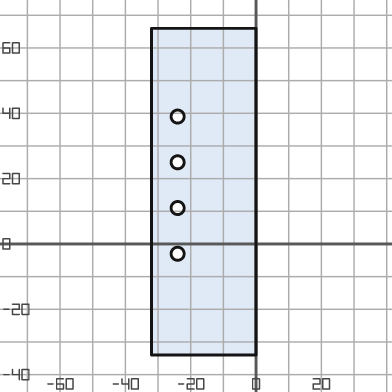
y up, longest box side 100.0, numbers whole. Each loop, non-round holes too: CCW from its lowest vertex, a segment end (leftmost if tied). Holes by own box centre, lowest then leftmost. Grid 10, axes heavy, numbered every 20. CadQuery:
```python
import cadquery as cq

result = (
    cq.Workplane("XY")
    .moveTo(-32.0, -34.0)
    .lineTo(0.0, -34.0)
    .lineTo(0.0, 66.0)
    .lineTo(-32.0, 66.0)
    .close()
    .moveTo(-24.0, -3.0)
    .circle(2.0)
    .moveTo(-24.0, 11.0)
    .circle(2.0)
    .moveTo(-24.0, 25.0)
    .circle(2.0)
    .moveTo(-24.0, 39.0)
    .circle(2.0)
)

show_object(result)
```